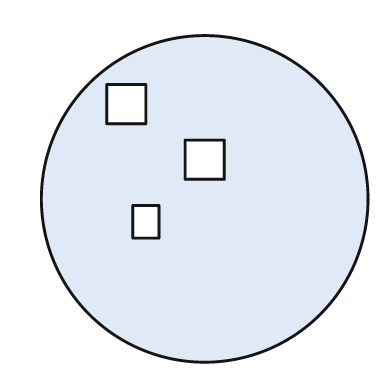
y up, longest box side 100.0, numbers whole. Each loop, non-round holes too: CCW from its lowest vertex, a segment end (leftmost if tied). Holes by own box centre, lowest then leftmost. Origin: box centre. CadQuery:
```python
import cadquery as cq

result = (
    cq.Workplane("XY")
    .moveTo(0.0, 0.0)
    .circle(50.0)
    .moveTo(-22.0, -12.0)
    .lineTo(-14.0, -12.0)
    .lineTo(-14.0, -2.0)
    .lineTo(-22.0, -2.0)
    .close()
    .moveTo(-6.0, 6.0)
    .lineTo(6.0, 6.0)
    .lineTo(6.0, 18.0)
    .lineTo(-6.0, 18.0)
    .close()
    .moveTo(-30.0, 23.0)
    .lineTo(-18.0, 23.0)
    .lineTo(-18.0, 35.0)
    .lineTo(-30.0, 35.0)
    .close()
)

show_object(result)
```